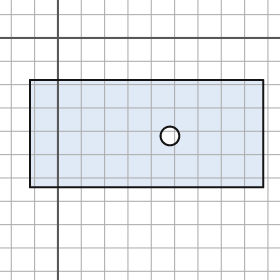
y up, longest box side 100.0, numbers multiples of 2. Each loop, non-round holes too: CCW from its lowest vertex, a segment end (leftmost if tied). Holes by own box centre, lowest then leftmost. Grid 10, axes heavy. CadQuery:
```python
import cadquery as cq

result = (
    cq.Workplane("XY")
    .moveTo(-12.0, -64.0)
    .lineTo(88.0, -64.0)
    .lineTo(88.0, -18.0)
    .lineTo(-12.0, -18.0)
    .close()
    .moveTo(48.0, -42.0)
    .circle(4.0)
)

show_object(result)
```